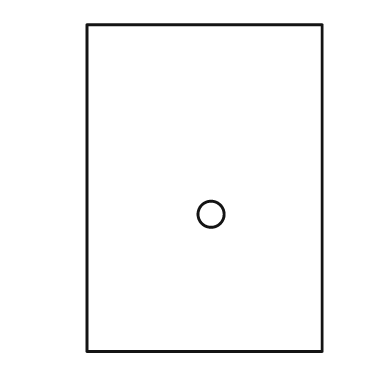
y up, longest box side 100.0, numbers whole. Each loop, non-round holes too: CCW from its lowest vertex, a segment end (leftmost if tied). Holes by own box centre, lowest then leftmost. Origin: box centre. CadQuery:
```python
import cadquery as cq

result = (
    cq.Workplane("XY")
    .moveTo(-36.0, -50.0)
    .lineTo(36.0, -50.0)
    .lineTo(36.0, 50.0)
    .lineTo(-36.0, 50.0)
    .close()
    .moveTo(2.0, -8.0)
    .circle(4.0)
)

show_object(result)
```